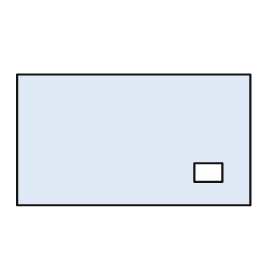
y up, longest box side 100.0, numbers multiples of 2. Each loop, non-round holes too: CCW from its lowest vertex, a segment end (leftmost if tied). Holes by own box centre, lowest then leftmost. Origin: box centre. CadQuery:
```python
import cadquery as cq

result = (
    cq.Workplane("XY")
    .moveTo(-50.0, -28.0)
    .lineTo(50.0, -28.0)
    .lineTo(50.0, 28.0)
    .lineTo(-50.0, 28.0)
    .close()
    .moveTo(26.0, -18.0)
    .lineTo(38.0, -18.0)
    .lineTo(38.0, -10.0)
    .lineTo(26.0, -10.0)
    .close()
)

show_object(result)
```